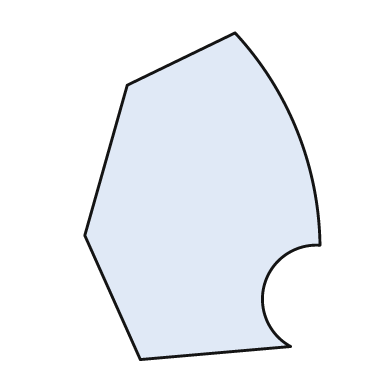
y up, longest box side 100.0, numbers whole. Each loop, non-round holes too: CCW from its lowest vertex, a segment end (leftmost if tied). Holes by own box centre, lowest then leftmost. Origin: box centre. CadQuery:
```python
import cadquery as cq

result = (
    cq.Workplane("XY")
    .moveTo(-19.0, -50.0)
    .lineTo(27.0, -46.0)
    .threePointArc((19.0, -27.0), (36.0, -15.0))
    .threePointArc((29.0, 20.0), (10.0, 50.0))
    .lineTo(-23.0, 34.0)
    .lineTo(-36.0, -12.0)
    .close()
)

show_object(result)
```